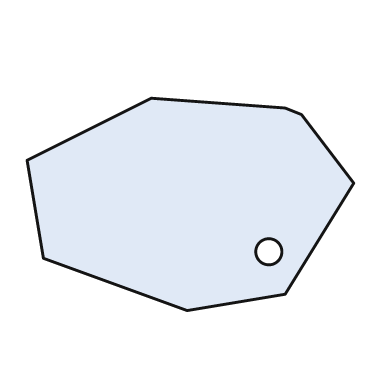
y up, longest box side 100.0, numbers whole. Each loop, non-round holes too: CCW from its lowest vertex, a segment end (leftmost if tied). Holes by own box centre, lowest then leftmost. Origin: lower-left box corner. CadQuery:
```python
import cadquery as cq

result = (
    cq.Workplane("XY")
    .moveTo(49.0, 0.0)
    .lineTo(79.0, 5.0)
    .lineTo(100.0, 39.0)
    .lineTo(84.0, 60.0)
    .lineTo(79.0, 62.0)
    .lineTo(38.0, 65.0)
    .lineTo(0.0, 46.0)
    .lineTo(5.0, 16.0)
    .close()
    .moveTo(74.0, 18.0)
    .circle(4.0)
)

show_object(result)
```